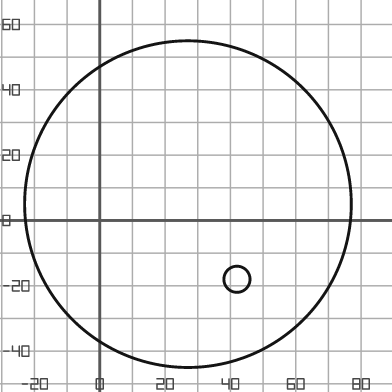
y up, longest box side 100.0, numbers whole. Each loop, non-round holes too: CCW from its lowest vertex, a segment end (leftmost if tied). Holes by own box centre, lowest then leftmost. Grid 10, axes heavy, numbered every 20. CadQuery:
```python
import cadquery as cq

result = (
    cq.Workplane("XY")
    .moveTo(27.0, 5.0)
    .circle(50.0)
    .moveTo(42.0, -18.0)
    .circle(4.0)
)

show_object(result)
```